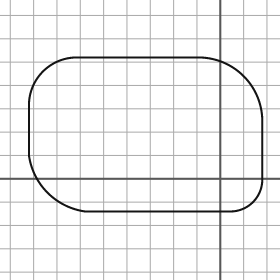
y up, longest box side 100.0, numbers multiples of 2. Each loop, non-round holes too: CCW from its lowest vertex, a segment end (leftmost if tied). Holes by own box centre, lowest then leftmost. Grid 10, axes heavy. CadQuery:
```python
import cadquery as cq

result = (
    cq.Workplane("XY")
    .moveTo(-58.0, -14.0)
    .lineTo(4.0, -14.0)
    .threePointArc((14.0, -10.0), (18.0, 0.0))
    .lineTo(18.0, 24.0)
    .threePointArc((10.0, 44.0), (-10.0, 52.0))
    .lineTo(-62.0, 52.0)
    .threePointArc((-76.0, 46.0), (-82.0, 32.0))
    .lineTo(-82.0, 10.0)
    .threePointArc((-74.0, -6.0), (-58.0, -14.0))
    .close()
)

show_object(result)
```